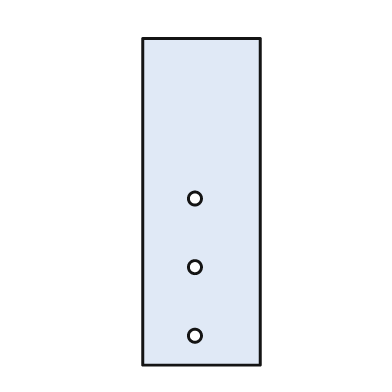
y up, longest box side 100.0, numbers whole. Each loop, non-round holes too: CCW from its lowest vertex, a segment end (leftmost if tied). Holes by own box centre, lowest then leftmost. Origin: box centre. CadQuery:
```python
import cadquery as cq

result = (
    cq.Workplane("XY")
    .moveTo(-18.0, -50.0)
    .lineTo(18.0, -50.0)
    .lineTo(18.0, 50.0)
    .lineTo(-18.0, 50.0)
    .close()
    .moveTo(-2.0, -41.0)
    .circle(2.0)
    .moveTo(-2.0, -20.0)
    .circle(2.0)
    .moveTo(-2.0, 1.0)
    .circle(2.0)
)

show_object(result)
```